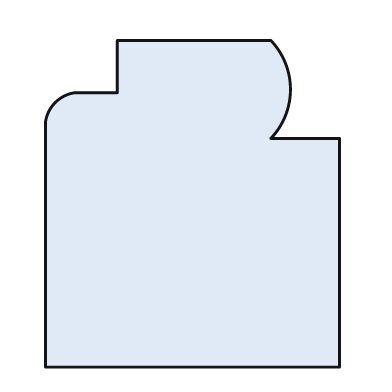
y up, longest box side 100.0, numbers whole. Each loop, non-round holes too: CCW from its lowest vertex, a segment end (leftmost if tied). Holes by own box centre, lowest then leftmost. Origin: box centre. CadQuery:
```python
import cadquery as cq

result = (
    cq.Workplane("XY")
    .moveTo(-45.0, -50.0)
    .lineTo(45.0, -50.0)
    .lineTo(45.0, 20.0)
    .lineTo(24.0, 20.0)
    .threePointArc((30.0, 35.0), (24.0, 50.0))
    .lineTo(-23.0, 50.0)
    .lineTo(-23.0, 34.0)
    .lineTo(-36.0, 34.0)
    .threePointArc((-42.0, 31.0), (-45.0, 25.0))
    .close()
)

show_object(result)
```